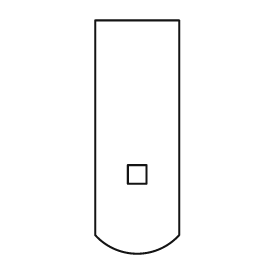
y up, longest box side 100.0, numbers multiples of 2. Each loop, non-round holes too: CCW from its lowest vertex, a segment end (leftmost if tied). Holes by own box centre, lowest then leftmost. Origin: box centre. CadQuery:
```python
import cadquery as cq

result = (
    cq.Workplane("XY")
    .moveTo(-18.0, -42.0)
    .threePointArc((0.0, -50.0), (18.0, -42.0))
    .lineTo(18.0, 50.0)
    .lineTo(-18.0, 50.0)
    .close()
    .moveTo(-4.0, -20.0)
    .lineTo(4.0, -20.0)
    .lineTo(4.0, -12.0)
    .lineTo(-4.0, -12.0)
    .close()
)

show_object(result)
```